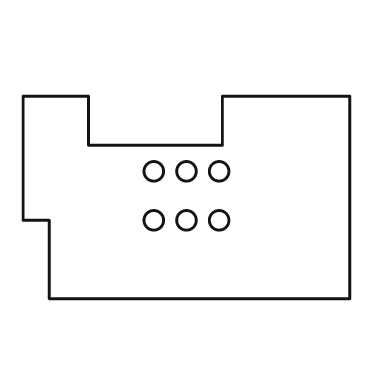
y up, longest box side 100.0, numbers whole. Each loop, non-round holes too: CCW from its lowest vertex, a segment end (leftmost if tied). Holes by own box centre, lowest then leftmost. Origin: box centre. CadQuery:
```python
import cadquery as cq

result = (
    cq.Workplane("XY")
    .moveTo(-42.0, -31.0)
    .lineTo(50.0, -31.0)
    .lineTo(50.0, 31.0)
    .lineTo(11.0, 31.0)
    .lineTo(11.0, 16.0)
    .lineTo(-30.0, 16.0)
    .lineTo(-30.0, 31.0)
    .lineTo(-50.0, 31.0)
    .lineTo(-50.0, -7.0)
    .lineTo(-42.0, -7.0)
    .close()
    .moveTo(-10.0, -7.0)
    .circle(3.0)
    .moveTo(0.0, -7.0)
    .circle(3.0)
    .moveTo(10.0, -7.0)
    .circle(3.0)
    .moveTo(-10.0, 8.0)
    .circle(3.0)
    .moveTo(0.0, 8.0)
    .circle(3.0)
    .moveTo(10.0, 8.0)
    .circle(3.0)
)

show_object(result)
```